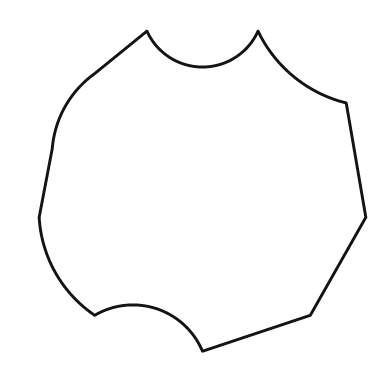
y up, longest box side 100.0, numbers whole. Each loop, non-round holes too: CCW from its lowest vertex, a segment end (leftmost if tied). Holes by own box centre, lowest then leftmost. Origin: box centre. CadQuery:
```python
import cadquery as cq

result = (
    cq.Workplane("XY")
    .moveTo(0.0, -49.0)
    .lineTo(33.0, -38.0)
    .lineTo(50.0, -8.0)
    .lineTo(44.0, 27.0)
    .threePointArc((28.0, 35.0), (17.0, 49.0))
    .threePointArc((0.0, 38.0), (-17.0, 49.0))
    .lineTo(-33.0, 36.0)
    .threePointArc((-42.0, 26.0), (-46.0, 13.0))
    .lineTo(-50.0, -8.0)
    .threePointArc((-45.0, -25.0), (-33.0, -38.0))
    .threePointArc((-14.0, -36.0), (0.0, -49.0))
    .close()
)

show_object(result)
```